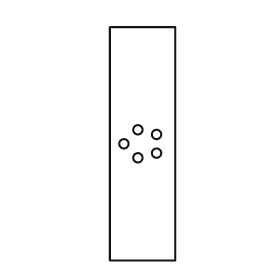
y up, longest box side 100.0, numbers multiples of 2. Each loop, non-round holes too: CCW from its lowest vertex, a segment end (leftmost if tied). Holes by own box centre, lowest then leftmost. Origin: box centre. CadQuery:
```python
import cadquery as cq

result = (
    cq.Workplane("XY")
    .moveTo(-14.0, -50.0)
    .lineTo(14.0, -50.0)
    .lineTo(14.0, 50.0)
    .lineTo(-14.0, 50.0)
    .close()
    .moveTo(-2.0, -6.0)
    .circle(2.0)
    .moveTo(6.0, -4.0)
    .circle(2.0)
    .moveTo(-8.0, 0.0)
    .circle(2.0)
    .moveTo(6.0, 4.0)
    .circle(2.0)
    .moveTo(-2.0, 6.0)
    .circle(2.0)
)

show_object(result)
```